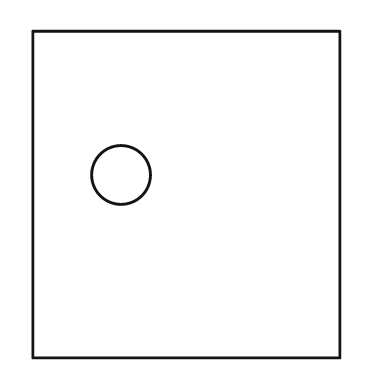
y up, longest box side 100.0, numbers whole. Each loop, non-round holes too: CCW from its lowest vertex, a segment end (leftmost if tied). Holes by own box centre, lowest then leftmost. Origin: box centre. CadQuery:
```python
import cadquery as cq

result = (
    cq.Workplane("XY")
    .moveTo(-47.0, -50.0)
    .lineTo(47.0, -50.0)
    .lineTo(47.0, 50.0)
    .lineTo(-47.0, 50.0)
    .close()
    .moveTo(-20.0, 6.0)
    .circle(9.0)
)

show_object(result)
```